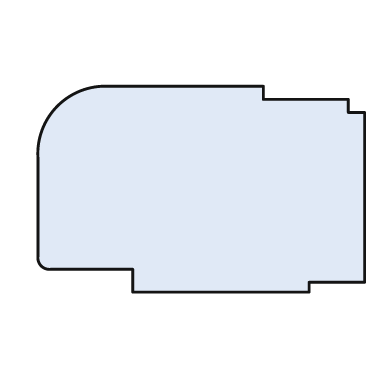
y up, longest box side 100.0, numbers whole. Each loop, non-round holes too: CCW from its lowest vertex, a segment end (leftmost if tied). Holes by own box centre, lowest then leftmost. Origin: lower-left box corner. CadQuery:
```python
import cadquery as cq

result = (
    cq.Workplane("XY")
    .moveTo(29.0, 0.0)
    .lineTo(83.0, 0.0)
    .lineTo(83.0, 3.0)
    .lineTo(100.0, 3.0)
    .lineTo(100.0, 55.0)
    .lineTo(95.0, 55.0)
    .lineTo(95.0, 59.0)
    .lineTo(69.0, 59.0)
    .lineTo(69.0, 63.0)
    .lineTo(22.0, 63.0)
    .threePointArc((6.0, 57.0), (0.0, 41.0))
    .lineTo(0.0, 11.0)
    .threePointArc((1.0, 8.0), (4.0, 7.0))
    .lineTo(29.0, 7.0)
    .close()
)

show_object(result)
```